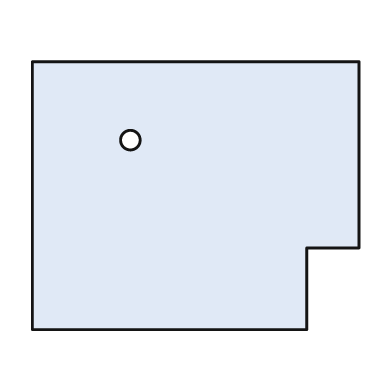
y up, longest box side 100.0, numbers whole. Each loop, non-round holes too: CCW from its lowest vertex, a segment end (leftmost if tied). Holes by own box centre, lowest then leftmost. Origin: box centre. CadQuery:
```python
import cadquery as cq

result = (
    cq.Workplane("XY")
    .moveTo(-50.0, -41.0)
    .lineTo(34.0, -41.0)
    .lineTo(34.0, -16.0)
    .lineTo(50.0, -16.0)
    .lineTo(50.0, 41.0)
    .lineTo(-50.0, 41.0)
    .close()
    .moveTo(-20.0, 17.0)
    .circle(3.0)
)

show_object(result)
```